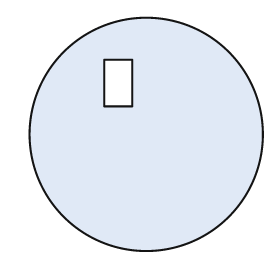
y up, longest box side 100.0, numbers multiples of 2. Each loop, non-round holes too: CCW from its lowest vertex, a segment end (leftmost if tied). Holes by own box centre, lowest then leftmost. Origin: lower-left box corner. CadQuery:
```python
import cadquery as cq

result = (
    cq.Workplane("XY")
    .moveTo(50.0, 50.0)
    .circle(50.0)
    .moveTo(32.0, 62.0)
    .lineTo(44.0, 62.0)
    .lineTo(44.0, 82.0)
    .lineTo(32.0, 82.0)
    .close()
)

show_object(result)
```